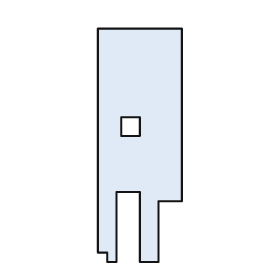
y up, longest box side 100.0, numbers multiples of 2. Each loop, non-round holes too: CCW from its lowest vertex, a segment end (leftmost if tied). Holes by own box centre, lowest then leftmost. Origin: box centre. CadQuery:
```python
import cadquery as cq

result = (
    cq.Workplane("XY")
    .moveTo(-14.0, -50.0)
    .lineTo(-10.0, -50.0)
    .lineTo(-10.0, -20.0)
    .lineTo(0.0, -20.0)
    .lineTo(0.0, -50.0)
    .lineTo(8.0, -50.0)
    .lineTo(8.0, -24.0)
    .lineTo(18.0, -24.0)
    .lineTo(18.0, 50.0)
    .lineTo(-18.0, 50.0)
    .lineTo(-18.0, -46.0)
    .lineTo(-14.0, -46.0)
    .close()
    .moveTo(-8.0, 4.0)
    .lineTo(0.0, 4.0)
    .lineTo(0.0, 12.0)
    .lineTo(-8.0, 12.0)
    .close()
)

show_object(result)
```